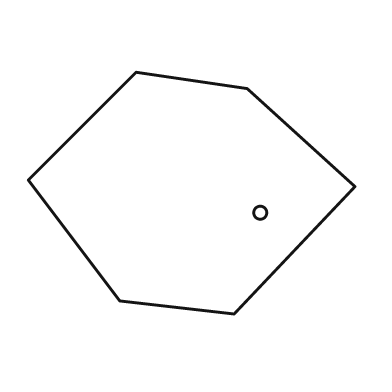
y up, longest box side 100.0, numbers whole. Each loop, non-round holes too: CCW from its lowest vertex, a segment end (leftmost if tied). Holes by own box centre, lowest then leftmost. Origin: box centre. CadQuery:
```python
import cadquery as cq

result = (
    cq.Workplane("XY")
    .moveTo(13.0, -37.0)
    .lineTo(50.0, 2.0)
    .lineTo(17.0, 32.0)
    .lineTo(-17.0, 37.0)
    .lineTo(-50.0, 4.0)
    .lineTo(-22.0, -33.0)
    .close()
    .moveTo(21.0, -6.0)
    .circle(2.0)
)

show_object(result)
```